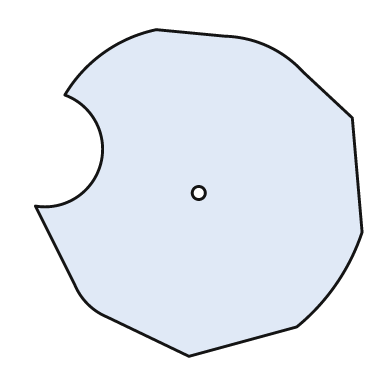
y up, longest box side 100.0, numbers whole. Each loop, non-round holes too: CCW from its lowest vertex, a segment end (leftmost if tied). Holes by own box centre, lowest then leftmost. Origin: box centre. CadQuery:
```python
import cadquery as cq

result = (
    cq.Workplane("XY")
    .moveTo(-3.0, -50.0)
    .lineTo(30.0, -41.0)
    .threePointArc((42.0, -28.0), (50.0, -12.0))
    .lineTo(47.0, 23.0)
    .lineTo(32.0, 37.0)
    .threePointArc((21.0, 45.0), (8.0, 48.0))
    .lineTo(-13.0, 50.0)
    .threePointArc((-29.0, 43.0), (-41.0, 30.0))
    .threePointArc((-30.0, 9.0), (-50.0, -4.0))
    .lineTo(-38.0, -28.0)
    .threePointArc((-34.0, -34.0), (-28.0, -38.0))
    .close()
    .moveTo(0.0, 0.0)
    .circle(2.0)
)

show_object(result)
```